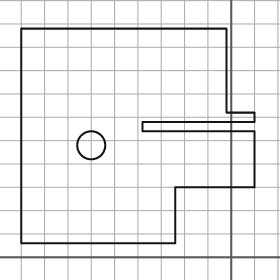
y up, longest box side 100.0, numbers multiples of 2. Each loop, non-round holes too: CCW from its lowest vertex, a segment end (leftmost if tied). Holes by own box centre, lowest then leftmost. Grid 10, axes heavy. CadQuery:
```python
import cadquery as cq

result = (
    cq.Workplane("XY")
    .moveTo(-90.0, 6.0)
    .lineTo(-24.0, 6.0)
    .lineTo(-24.0, 30.0)
    .lineTo(10.0, 30.0)
    .lineTo(10.0, 54.0)
    .lineTo(-38.0, 54.0)
    .lineTo(-38.0, 58.0)
    .lineTo(10.0, 58.0)
    .lineTo(10.0, 62.0)
    .lineTo(-2.0, 62.0)
    .lineTo(-2.0, 98.0)
    .lineTo(-90.0, 98.0)
    .close()
    .moveTo(-60.0, 48.0)
    .circle(6.0)
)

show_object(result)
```